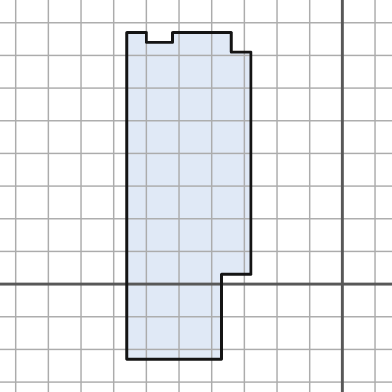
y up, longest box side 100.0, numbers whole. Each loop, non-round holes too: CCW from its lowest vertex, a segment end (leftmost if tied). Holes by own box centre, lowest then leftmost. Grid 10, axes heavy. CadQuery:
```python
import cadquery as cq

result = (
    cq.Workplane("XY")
    .moveTo(-66.0, -23.0)
    .lineTo(-37.0, -23.0)
    .lineTo(-37.0, 3.0)
    .lineTo(-28.0, 3.0)
    .lineTo(-28.0, 71.0)
    .lineTo(-34.0, 71.0)
    .lineTo(-34.0, 77.0)
    .lineTo(-52.0, 77.0)
    .lineTo(-52.0, 74.0)
    .lineTo(-60.0, 74.0)
    .lineTo(-60.0, 77.0)
    .lineTo(-66.0, 77.0)
    .close()
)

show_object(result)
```